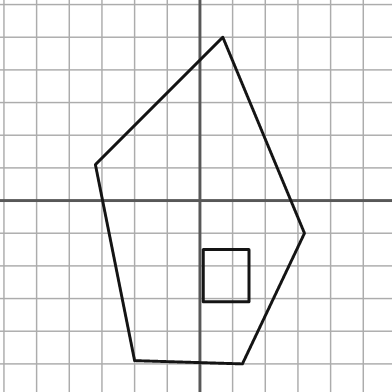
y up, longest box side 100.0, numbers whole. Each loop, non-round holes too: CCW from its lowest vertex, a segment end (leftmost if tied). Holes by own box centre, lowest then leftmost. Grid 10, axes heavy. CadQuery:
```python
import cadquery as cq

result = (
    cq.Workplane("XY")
    .moveTo(13.0, -50.0)
    .lineTo(32.0, -10.0)
    .lineTo(7.0, 50.0)
    .lineTo(-32.0, 11.0)
    .lineTo(-20.0, -49.0)
    .close()
    .moveTo(1.0, -31.0)
    .lineTo(15.0, -31.0)
    .lineTo(15.0, -15.0)
    .lineTo(1.0, -15.0)
    .close()
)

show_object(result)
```